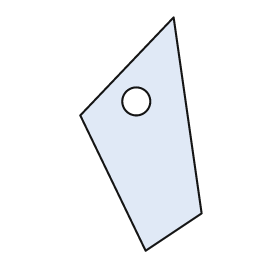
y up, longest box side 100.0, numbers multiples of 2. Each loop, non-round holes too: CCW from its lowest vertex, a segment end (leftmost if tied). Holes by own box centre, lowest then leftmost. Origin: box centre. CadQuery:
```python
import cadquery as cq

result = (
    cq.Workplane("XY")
    .moveTo(2.0, -50.0)
    .lineTo(26.0, -34.0)
    .lineTo(14.0, 50.0)
    .lineTo(-26.0, 8.0)
    .close()
    .moveTo(-2.0, 14.0)
    .circle(6.0)
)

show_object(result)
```